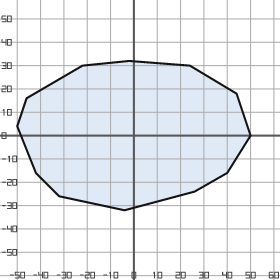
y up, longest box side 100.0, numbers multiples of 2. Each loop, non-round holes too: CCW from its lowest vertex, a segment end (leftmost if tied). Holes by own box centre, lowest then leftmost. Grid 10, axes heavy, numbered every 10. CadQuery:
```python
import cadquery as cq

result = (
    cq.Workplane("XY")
    .moveTo(-4.0, -32.0)
    .lineTo(26.0, -24.0)
    .lineTo(40.0, -16.0)
    .lineTo(50.0, 0.0)
    .lineTo(44.0, 18.0)
    .lineTo(24.0, 30.0)
    .lineTo(-2.0, 32.0)
    .lineTo(-22.0, 30.0)
    .lineTo(-46.0, 16.0)
    .lineTo(-50.0, 4.0)
    .lineTo(-42.0, -16.0)
    .lineTo(-32.0, -26.0)
    .close()
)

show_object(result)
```